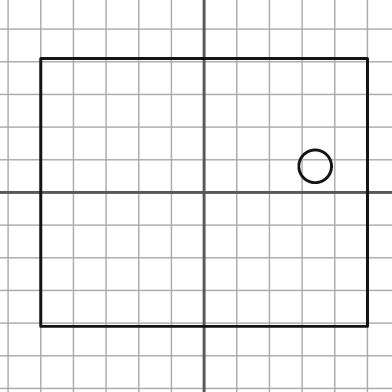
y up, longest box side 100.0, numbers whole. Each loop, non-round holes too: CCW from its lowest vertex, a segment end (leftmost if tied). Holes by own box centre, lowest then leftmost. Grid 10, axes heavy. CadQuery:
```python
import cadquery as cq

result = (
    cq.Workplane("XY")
    .moveTo(-50.0, -41.0)
    .lineTo(50.0, -41.0)
    .lineTo(50.0, 41.0)
    .lineTo(-50.0, 41.0)
    .close()
    .moveTo(34.0, 8.0)
    .circle(5.0)
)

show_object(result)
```